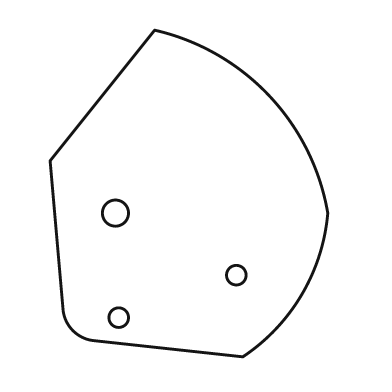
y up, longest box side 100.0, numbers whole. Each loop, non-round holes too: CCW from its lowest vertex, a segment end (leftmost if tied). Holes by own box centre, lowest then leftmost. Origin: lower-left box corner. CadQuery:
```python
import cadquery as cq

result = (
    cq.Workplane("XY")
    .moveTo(59.0, 0.0)
    .threePointArc((77.0, 19.0), (85.0, 44.0))
    .threePointArc((67.0, 80.0), (32.0, 100.0))
    .lineTo(0.0, 60.0)
    .lineTo(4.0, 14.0)
    .threePointArc((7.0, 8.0), (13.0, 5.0))
    .close()
    .moveTo(21.0, 12.0)
    .circle(3.0)
    .moveTo(57.0, 25.0)
    .circle(3.0)
    .moveTo(20.0, 44.0)
    .circle(4.0)
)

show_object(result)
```